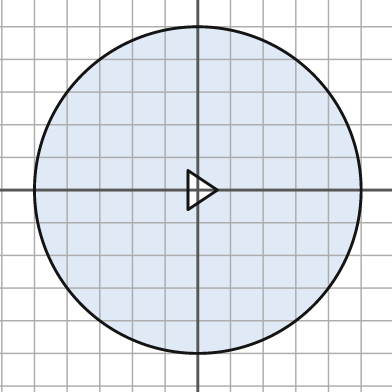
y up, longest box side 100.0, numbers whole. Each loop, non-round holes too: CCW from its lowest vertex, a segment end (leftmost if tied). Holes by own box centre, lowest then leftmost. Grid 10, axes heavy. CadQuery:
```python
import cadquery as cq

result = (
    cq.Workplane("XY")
    .moveTo(0.0, 0.0)
    .circle(50.0)
    .moveTo(-3.0, -6.0)
    .lineTo(6.0, 0.0)
    .lineTo(-3.0, 6.0)
    .close()
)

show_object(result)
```